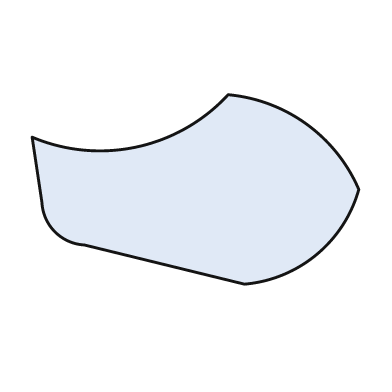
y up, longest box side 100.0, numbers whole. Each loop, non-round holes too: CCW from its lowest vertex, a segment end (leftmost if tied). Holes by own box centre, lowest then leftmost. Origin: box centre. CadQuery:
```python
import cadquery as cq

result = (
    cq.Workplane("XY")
    .moveTo(15.0, -29.0)
    .threePointArc((37.0, -20.0), (50.0, 0.0))
    .threePointArc((34.0, 20.0), (10.0, 29.0))
    .threePointArc((-18.0, 13.0), (-50.0, 16.0))
    .lineTo(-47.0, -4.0)
    .threePointArc((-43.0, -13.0), (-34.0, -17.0))
    .close()
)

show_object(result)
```